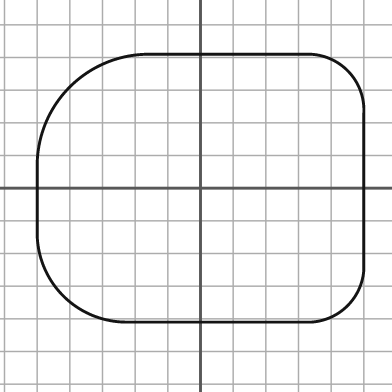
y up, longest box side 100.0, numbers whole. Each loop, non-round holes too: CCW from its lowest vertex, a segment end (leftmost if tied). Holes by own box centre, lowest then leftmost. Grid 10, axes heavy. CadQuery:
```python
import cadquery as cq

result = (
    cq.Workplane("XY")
    .moveTo(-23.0, -41.0)
    .lineTo(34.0, -41.0)
    .threePointArc((45.0, -36.0), (50.0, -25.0))
    .lineTo(50.0, 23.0)
    .threePointArc((45.0, 36.0), (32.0, 41.0))
    .lineTo(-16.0, 41.0)
    .threePointArc((-40.0, 31.0), (-50.0, 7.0))
    .lineTo(-50.0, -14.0)
    .threePointArc((-42.0, -33.0), (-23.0, -41.0))
    .close()
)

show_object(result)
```